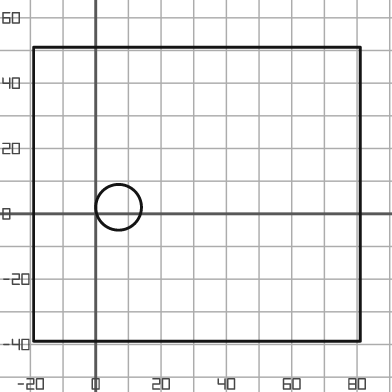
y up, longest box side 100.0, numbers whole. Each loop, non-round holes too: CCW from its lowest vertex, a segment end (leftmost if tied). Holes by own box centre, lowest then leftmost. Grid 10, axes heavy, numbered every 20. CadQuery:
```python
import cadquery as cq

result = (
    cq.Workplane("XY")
    .moveTo(-19.0, -39.0)
    .lineTo(81.0, -39.0)
    .lineTo(81.0, 51.0)
    .lineTo(-19.0, 51.0)
    .close()
    .moveTo(7.0, 2.0)
    .circle(7.0)
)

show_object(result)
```